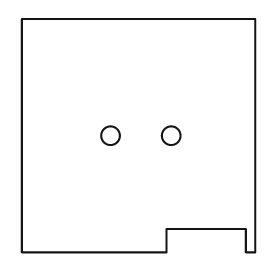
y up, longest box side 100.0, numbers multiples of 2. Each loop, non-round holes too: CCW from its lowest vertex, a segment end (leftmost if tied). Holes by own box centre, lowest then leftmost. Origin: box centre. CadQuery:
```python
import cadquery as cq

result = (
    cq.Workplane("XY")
    .moveTo(-50.0, -50.0)
    .lineTo(12.0, -50.0)
    .lineTo(12.0, -40.0)
    .lineTo(46.0, -40.0)
    .lineTo(46.0, -50.0)
    .lineTo(50.0, -50.0)
    .lineTo(50.0, 50.0)
    .lineTo(-50.0, 50.0)
    .close()
    .moveTo(-12.0, 0.0)
    .circle(4.0)
    .moveTo(14.0, 0.0)
    .circle(4.0)
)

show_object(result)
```